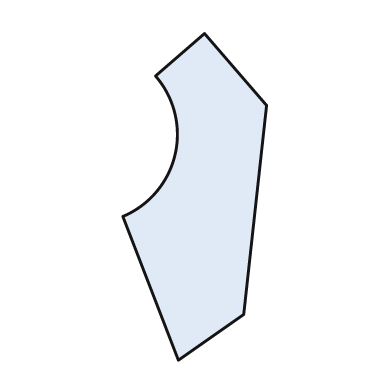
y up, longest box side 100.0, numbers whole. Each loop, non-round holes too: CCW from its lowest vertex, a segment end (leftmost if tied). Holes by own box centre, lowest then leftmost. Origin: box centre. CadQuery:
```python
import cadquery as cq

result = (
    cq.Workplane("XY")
    .moveTo(-5.0, -50.0)
    .lineTo(15.0, -36.0)
    .lineTo(22.0, 28.0)
    .lineTo(3.0, 50.0)
    .lineTo(-12.0, 37.0)
    .threePointArc((-6.0, 13.0), (-22.0, -6.0))
    .close()
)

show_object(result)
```